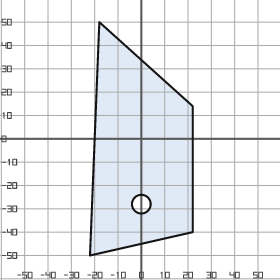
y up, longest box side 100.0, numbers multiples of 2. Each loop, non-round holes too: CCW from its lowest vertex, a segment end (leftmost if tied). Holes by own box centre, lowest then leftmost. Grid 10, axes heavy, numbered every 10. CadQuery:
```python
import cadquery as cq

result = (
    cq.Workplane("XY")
    .moveTo(-22.0, -50.0)
    .lineTo(22.0, -40.0)
    .lineTo(22.0, 14.0)
    .lineTo(-18.0, 50.0)
    .close()
    .moveTo(0.0, -28.0)
    .circle(4.0)
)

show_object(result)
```